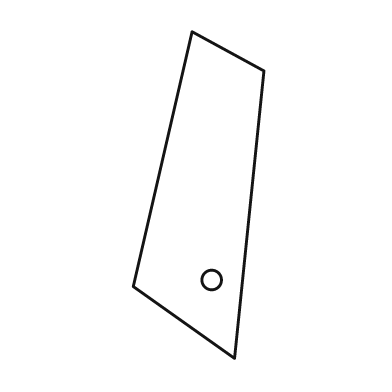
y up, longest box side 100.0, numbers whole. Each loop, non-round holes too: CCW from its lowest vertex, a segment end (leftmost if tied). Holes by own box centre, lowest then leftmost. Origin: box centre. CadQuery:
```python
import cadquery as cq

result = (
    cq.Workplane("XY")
    .moveTo(11.0, -50.0)
    .lineTo(20.0, 38.0)
    .lineTo(-2.0, 50.0)
    .lineTo(-20.0, -28.0)
    .close()
    .moveTo(4.0, -26.0)
    .circle(3.0)
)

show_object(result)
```